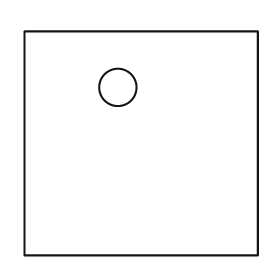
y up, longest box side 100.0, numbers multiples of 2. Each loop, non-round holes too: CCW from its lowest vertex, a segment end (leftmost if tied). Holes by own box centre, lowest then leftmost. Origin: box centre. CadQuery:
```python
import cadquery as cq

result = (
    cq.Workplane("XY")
    .moveTo(-50.0, -48.0)
    .lineTo(50.0, -48.0)
    .lineTo(50.0, 48.0)
    .lineTo(-50.0, 48.0)
    .close()
    .moveTo(-10.0, 24.0)
    .circle(8.0)
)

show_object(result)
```